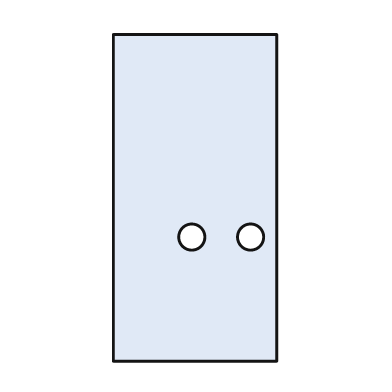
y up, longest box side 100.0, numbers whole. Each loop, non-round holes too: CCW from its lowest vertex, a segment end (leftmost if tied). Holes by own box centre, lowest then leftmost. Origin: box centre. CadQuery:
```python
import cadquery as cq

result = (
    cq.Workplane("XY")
    .moveTo(-25.0, -50.0)
    .lineTo(25.0, -50.0)
    .lineTo(25.0, 50.0)
    .lineTo(-25.0, 50.0)
    .close()
    .moveTo(-1.0, -12.0)
    .circle(4.0)
    .moveTo(17.0, -12.0)
    .circle(4.0)
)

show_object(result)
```